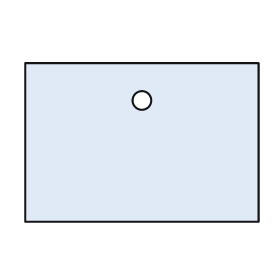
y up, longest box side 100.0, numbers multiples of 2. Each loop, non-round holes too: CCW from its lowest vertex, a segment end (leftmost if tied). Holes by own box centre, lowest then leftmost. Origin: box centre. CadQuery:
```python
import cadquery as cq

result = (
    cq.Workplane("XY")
    .moveTo(-50.0, -34.0)
    .lineTo(50.0, -34.0)
    .lineTo(50.0, 34.0)
    .lineTo(-50.0, 34.0)
    .close()
    .moveTo(0.0, 18.0)
    .circle(4.0)
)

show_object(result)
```